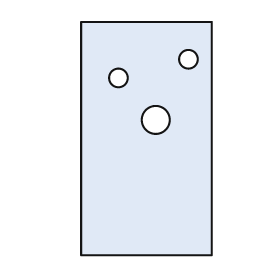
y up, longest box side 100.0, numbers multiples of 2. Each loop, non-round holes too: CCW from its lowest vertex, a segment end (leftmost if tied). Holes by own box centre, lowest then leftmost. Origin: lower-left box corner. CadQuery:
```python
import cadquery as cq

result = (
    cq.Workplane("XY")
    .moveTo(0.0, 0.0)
    .lineTo(56.0, 0.0)
    .lineTo(56.0, 100.0)
    .lineTo(0.0, 100.0)
    .close()
    .moveTo(32.0, 58.0)
    .circle(6.0)
    .moveTo(16.0, 76.0)
    .circle(4.0)
    .moveTo(46.0, 84.0)
    .circle(4.0)
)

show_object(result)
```